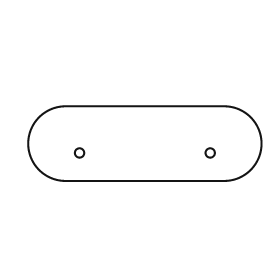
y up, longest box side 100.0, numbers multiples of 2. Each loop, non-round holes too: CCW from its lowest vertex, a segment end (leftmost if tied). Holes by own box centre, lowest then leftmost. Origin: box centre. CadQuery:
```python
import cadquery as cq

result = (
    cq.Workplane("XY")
    .moveTo(-34.0, -16.0)
    .lineTo(34.0, -16.0)
    .threePointArc((50.0, 0.0), (34.0, 16.0))
    .lineTo(-34.0, 16.0)
    .threePointArc((-50.0, 0.0), (-34.0, -16.0))
    .close()
    .moveTo(-28.0, -4.0)
    .circle(2.0)
    .moveTo(28.0, -4.0)
    .circle(2.0)
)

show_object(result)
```